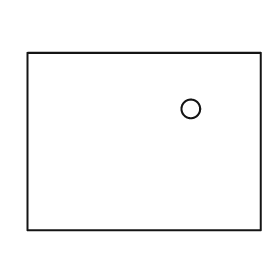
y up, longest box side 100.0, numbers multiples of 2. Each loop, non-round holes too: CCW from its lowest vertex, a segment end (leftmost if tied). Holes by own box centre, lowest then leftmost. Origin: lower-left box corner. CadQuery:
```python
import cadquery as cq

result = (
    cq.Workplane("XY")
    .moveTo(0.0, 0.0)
    .lineTo(100.0, 0.0)
    .lineTo(100.0, 76.0)
    .lineTo(0.0, 76.0)
    .close()
    .moveTo(70.0, 52.0)
    .circle(4.0)
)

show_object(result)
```